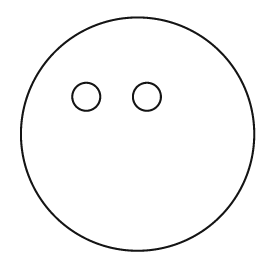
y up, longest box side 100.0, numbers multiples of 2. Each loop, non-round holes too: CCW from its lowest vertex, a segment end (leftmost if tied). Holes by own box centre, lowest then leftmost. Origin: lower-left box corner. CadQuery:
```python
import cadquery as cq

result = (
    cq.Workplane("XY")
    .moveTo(50.0, 50.0)
    .circle(50.0)
    .moveTo(28.0, 66.0)
    .circle(6.0)
    .moveTo(54.0, 66.0)
    .circle(6.0)
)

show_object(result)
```